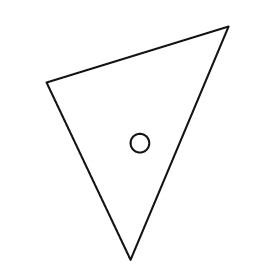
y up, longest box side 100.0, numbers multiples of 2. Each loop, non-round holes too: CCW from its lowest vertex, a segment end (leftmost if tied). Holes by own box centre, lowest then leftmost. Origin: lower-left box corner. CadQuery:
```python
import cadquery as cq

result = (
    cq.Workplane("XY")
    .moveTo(36.0, 0.0)
    .lineTo(78.0, 100.0)
    .lineTo(0.0, 76.0)
    .close()
    .moveTo(40.0, 50.0)
    .circle(4.0)
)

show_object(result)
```